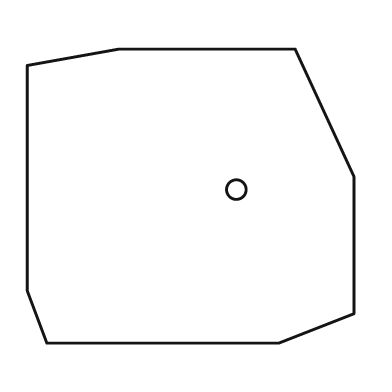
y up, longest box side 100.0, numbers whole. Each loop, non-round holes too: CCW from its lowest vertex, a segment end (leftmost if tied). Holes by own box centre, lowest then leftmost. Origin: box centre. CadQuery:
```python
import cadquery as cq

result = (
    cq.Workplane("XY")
    .moveTo(-44.0, -45.0)
    .lineTo(27.0, -45.0)
    .lineTo(50.0, -36.0)
    .lineTo(50.0, 6.0)
    .lineTo(32.0, 45.0)
    .lineTo(-22.0, 45.0)
    .lineTo(-50.0, 40.0)
    .lineTo(-50.0, -29.0)
    .close()
    .moveTo(14.0, 2.0)
    .circle(3.0)
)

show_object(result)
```